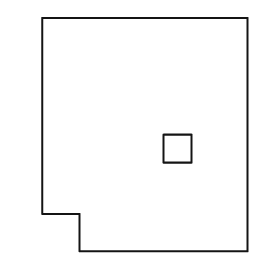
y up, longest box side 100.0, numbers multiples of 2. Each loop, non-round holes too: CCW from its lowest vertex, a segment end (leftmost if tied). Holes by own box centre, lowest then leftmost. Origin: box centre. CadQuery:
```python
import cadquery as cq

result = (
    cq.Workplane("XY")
    .moveTo(-28.0, -50.0)
    .lineTo(44.0, -50.0)
    .lineTo(44.0, 50.0)
    .lineTo(-44.0, 50.0)
    .lineTo(-44.0, -34.0)
    .lineTo(-28.0, -34.0)
    .close()
    .moveTo(8.0, -12.0)
    .lineTo(20.0, -12.0)
    .lineTo(20.0, 0.0)
    .lineTo(8.0, 0.0)
    .close()
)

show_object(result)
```